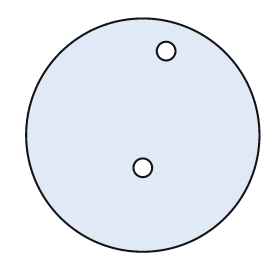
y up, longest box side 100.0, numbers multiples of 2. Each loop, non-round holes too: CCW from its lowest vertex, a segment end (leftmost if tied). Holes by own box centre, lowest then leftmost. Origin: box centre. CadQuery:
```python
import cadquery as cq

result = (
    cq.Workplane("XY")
    .moveTo(0.0, 0.0)
    .circle(50.0)
    .moveTo(0.0, -14.0)
    .circle(4.0)
    .moveTo(10.0, 36.0)
    .circle(4.0)
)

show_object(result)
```